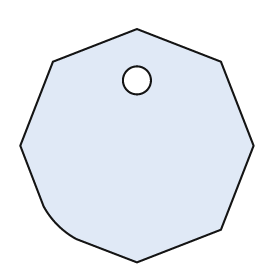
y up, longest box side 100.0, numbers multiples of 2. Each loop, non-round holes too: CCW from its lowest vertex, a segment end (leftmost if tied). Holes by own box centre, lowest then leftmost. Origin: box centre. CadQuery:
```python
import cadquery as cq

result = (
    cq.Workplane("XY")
    .moveTo(0.0, -50.0)
    .lineTo(36.0, -36.0)
    .lineTo(50.0, 0.0)
    .lineTo(36.0, 36.0)
    .lineTo(0.0, 50.0)
    .lineTo(-36.0, 36.0)
    .lineTo(-50.0, 0.0)
    .lineTo(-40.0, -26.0)
    .threePointArc((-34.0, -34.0), (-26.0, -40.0))
    .close()
    .moveTo(0.0, 28.0)
    .circle(6.0)
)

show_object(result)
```